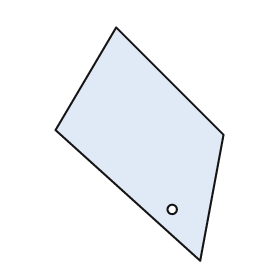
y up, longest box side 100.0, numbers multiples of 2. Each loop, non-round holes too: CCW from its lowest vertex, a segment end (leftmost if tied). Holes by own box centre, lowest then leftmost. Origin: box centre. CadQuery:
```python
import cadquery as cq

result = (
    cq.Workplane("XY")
    .moveTo(26.0, -50.0)
    .lineTo(36.0, 4.0)
    .lineTo(-10.0, 50.0)
    .lineTo(-36.0, 6.0)
    .close()
    .moveTo(14.0, -28.0)
    .circle(2.0)
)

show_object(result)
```